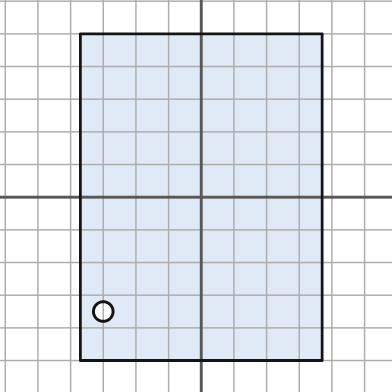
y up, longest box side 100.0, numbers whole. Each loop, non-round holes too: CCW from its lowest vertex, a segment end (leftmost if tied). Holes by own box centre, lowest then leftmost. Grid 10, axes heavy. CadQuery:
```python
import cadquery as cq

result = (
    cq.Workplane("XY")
    .moveTo(-37.0, -50.0)
    .lineTo(37.0, -50.0)
    .lineTo(37.0, 50.0)
    .lineTo(-37.0, 50.0)
    .close()
    .moveTo(-30.0, -35.0)
    .circle(3.0)
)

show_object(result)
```